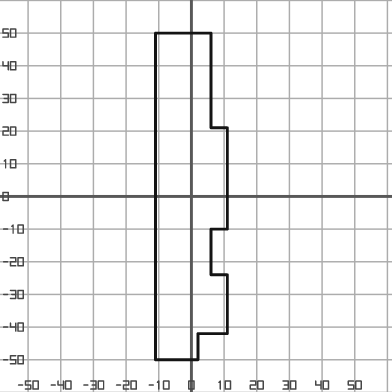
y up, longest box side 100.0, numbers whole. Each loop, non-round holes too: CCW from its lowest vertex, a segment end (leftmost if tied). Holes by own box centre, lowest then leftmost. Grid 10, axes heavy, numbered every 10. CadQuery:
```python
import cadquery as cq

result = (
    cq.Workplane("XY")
    .moveTo(-11.0, -50.0)
    .lineTo(2.0, -50.0)
    .lineTo(2.0, -42.0)
    .lineTo(11.0, -42.0)
    .lineTo(11.0, -24.0)
    .lineTo(6.0, -24.0)
    .lineTo(6.0, -10.0)
    .lineTo(11.0, -10.0)
    .lineTo(11.0, 21.0)
    .lineTo(6.0, 21.0)
    .lineTo(6.0, 50.0)
    .lineTo(-11.0, 50.0)
    .close()
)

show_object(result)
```